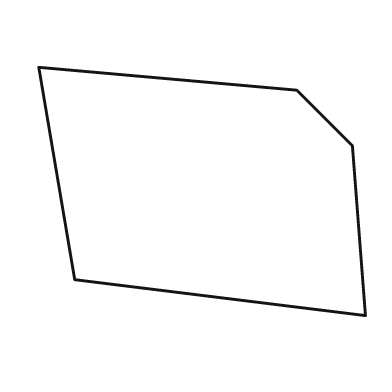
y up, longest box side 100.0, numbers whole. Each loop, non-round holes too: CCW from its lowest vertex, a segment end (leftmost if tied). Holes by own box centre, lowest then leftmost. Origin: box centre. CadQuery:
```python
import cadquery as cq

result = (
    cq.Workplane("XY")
    .moveTo(50.0, -38.0)
    .lineTo(46.0, 14.0)
    .lineTo(29.0, 31.0)
    .lineTo(-50.0, 38.0)
    .lineTo(-39.0, -27.0)
    .close()
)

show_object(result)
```